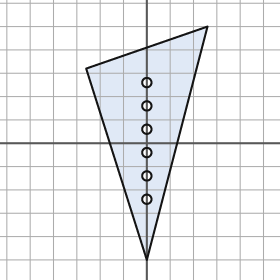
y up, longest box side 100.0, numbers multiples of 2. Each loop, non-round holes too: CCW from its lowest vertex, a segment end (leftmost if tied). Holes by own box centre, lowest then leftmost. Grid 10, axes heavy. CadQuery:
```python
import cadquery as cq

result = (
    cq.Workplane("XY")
    .moveTo(0.0, -50.0)
    .lineTo(26.0, 50.0)
    .lineTo(-26.0, 32.0)
    .close()
    .moveTo(0.0, -24.0)
    .circle(2.0)
    .moveTo(0.0, -14.0)
    .circle(2.0)
    .moveTo(0.0, -4.0)
    .circle(2.0)
    .moveTo(0.0, 6.0)
    .circle(2.0)
    .moveTo(0.0, 16.0)
    .circle(2.0)
    .moveTo(0.0, 26.0)
    .circle(2.0)
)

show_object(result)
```